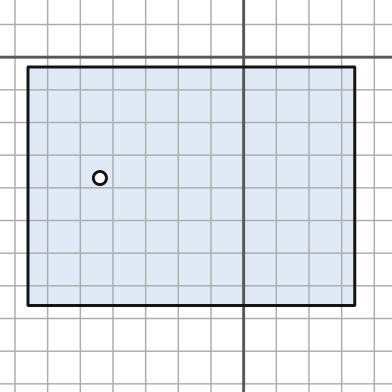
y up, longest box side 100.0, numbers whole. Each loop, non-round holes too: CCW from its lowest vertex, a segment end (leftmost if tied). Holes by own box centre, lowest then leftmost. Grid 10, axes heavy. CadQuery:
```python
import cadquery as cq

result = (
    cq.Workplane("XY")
    .moveTo(-66.0, -76.0)
    .lineTo(34.0, -76.0)
    .lineTo(34.0, -3.0)
    .lineTo(-66.0, -3.0)
    .close()
    .moveTo(-44.0, -37.0)
    .circle(2.0)
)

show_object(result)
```